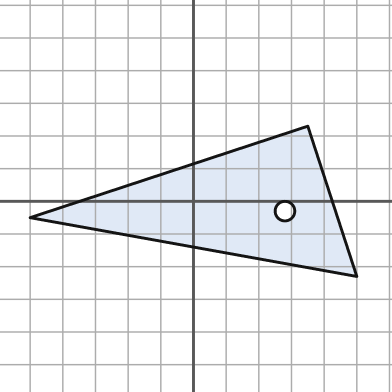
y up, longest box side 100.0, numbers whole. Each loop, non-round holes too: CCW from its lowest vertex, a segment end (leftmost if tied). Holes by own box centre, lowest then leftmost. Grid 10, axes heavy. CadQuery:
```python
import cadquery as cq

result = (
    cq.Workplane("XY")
    .moveTo(50.0, -23.0)
    .lineTo(35.0, 23.0)
    .lineTo(-50.0, -5.0)
    .close()
    .moveTo(28.0, -3.0)
    .circle(3.0)
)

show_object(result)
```